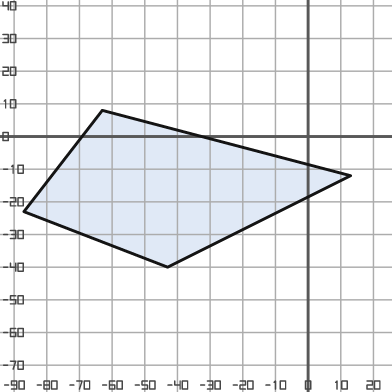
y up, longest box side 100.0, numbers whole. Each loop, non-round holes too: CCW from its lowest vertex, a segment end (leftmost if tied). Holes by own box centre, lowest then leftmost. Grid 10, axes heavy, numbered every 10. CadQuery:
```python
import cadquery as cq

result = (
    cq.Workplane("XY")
    .moveTo(-43.0, -40.0)
    .lineTo(13.0, -12.0)
    .lineTo(-63.0, 8.0)
    .lineTo(-87.0, -23.0)
    .close()
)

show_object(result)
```